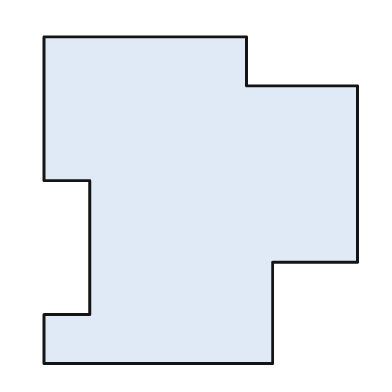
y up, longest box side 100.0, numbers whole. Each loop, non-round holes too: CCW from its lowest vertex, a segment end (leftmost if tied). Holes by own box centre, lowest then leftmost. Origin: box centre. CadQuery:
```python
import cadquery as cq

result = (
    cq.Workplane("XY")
    .moveTo(-48.0, -50.0)
    .lineTo(22.0, -50.0)
    .lineTo(22.0, -19.0)
    .lineTo(48.0, -19.0)
    .lineTo(48.0, 35.0)
    .lineTo(14.0, 35.0)
    .lineTo(14.0, 50.0)
    .lineTo(-48.0, 50.0)
    .lineTo(-48.0, 6.0)
    .lineTo(-34.0, 6.0)
    .lineTo(-34.0, -35.0)
    .lineTo(-48.0, -35.0)
    .close()
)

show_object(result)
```